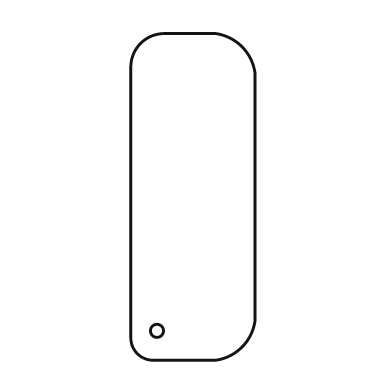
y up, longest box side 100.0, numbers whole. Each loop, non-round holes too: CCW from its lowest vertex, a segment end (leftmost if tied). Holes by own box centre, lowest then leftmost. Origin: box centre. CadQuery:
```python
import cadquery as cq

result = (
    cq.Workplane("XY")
    .moveTo(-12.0, -50.0)
    .lineTo(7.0, -50.0)
    .threePointArc((15.0, -46.0), (19.0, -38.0))
    .lineTo(19.0, 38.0)
    .threePointArc((15.0, 46.0), (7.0, 50.0))
    .lineTo(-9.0, 50.0)
    .threePointArc((-16.0, 47.0), (-19.0, 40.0))
    .lineTo(-19.0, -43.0)
    .threePointArc((-17.0, -48.0), (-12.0, -50.0))
    .close()
    .moveTo(-11.0, -41.0)
    .circle(2.0)
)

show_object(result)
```